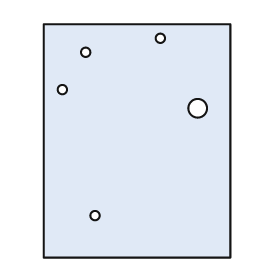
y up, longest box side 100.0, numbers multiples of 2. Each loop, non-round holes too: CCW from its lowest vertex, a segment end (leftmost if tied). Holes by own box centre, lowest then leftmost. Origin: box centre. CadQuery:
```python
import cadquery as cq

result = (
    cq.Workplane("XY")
    .moveTo(-40.0, -50.0)
    .lineTo(40.0, -50.0)
    .lineTo(40.0, 50.0)
    .lineTo(-40.0, 50.0)
    .close()
    .moveTo(-18.0, -32.0)
    .circle(2.0)
    .moveTo(26.0, 14.0)
    .circle(4.0)
    .moveTo(-32.0, 22.0)
    .circle(2.0)
    .moveTo(-22.0, 38.0)
    .circle(2.0)
    .moveTo(10.0, 44.0)
    .circle(2.0)
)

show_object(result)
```